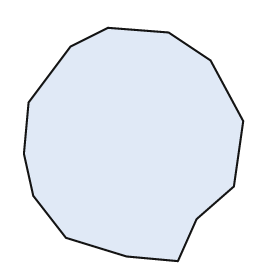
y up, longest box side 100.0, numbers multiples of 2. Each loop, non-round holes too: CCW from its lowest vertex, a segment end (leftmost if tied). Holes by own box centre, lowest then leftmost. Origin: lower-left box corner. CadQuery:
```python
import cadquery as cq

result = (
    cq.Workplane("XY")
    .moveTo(66.0, 0.0)
    .lineTo(74.0, 18.0)
    .lineTo(90.0, 32.0)
    .lineTo(94.0, 60.0)
    .lineTo(80.0, 86.0)
    .lineTo(62.0, 98.0)
    .lineTo(36.0, 100.0)
    .lineTo(20.0, 92.0)
    .lineTo(2.0, 68.0)
    .lineTo(0.0, 46.0)
    .lineTo(4.0, 28.0)
    .lineTo(18.0, 10.0)
    .lineTo(44.0, 2.0)
    .close()
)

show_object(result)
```